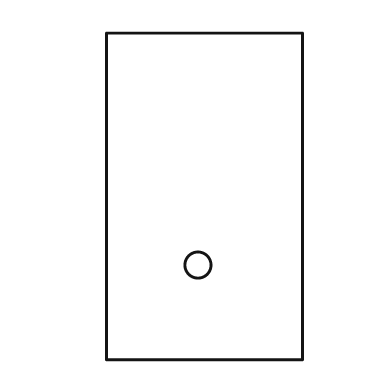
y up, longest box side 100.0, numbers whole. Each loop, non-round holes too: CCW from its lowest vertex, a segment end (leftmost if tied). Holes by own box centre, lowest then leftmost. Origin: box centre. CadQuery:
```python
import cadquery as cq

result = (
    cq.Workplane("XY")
    .moveTo(-30.0, -50.0)
    .lineTo(30.0, -50.0)
    .lineTo(30.0, 50.0)
    .lineTo(-30.0, 50.0)
    .close()
    .moveTo(-2.0, -21.0)
    .circle(4.0)
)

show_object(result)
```